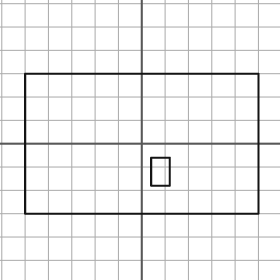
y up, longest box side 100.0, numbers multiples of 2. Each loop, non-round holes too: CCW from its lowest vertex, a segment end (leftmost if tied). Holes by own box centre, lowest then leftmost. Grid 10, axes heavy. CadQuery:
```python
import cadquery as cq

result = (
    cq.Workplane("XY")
    .moveTo(-50.0, -30.0)
    .lineTo(50.0, -30.0)
    .lineTo(50.0, 30.0)
    .lineTo(-50.0, 30.0)
    .close()
    .moveTo(4.0, -18.0)
    .lineTo(12.0, -18.0)
    .lineTo(12.0, -6.0)
    .lineTo(4.0, -6.0)
    .close()
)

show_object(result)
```